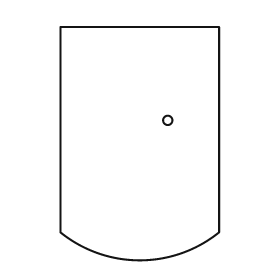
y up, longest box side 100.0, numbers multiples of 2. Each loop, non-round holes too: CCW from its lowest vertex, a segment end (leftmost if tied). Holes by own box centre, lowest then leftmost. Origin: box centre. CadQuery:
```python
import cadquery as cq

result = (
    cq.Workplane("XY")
    .moveTo(-34.0, -38.0)
    .threePointArc((0.0, -50.0), (34.0, -38.0))
    .lineTo(34.0, 50.0)
    .lineTo(-34.0, 50.0)
    .close()
    .moveTo(12.0, 10.0)
    .circle(2.0)
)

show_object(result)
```